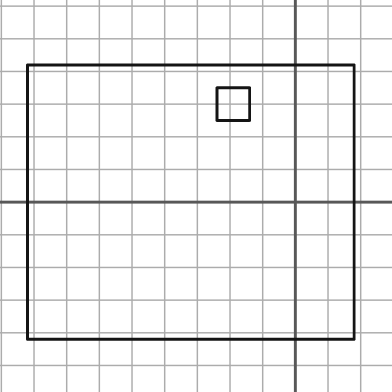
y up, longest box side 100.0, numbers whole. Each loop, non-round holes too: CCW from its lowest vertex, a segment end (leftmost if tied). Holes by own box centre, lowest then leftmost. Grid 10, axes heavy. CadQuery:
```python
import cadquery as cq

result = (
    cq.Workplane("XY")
    .moveTo(-82.0, -42.0)
    .lineTo(18.0, -42.0)
    .lineTo(18.0, 42.0)
    .lineTo(-82.0, 42.0)
    .close()
    .moveTo(-24.0, 25.0)
    .lineTo(-14.0, 25.0)
    .lineTo(-14.0, 35.0)
    .lineTo(-24.0, 35.0)
    .close()
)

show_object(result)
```